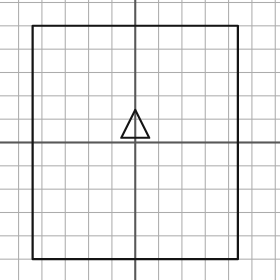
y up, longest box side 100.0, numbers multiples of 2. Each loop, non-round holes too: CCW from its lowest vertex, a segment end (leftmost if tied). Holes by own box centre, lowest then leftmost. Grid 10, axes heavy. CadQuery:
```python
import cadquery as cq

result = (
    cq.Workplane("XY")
    .moveTo(-44.0, -50.0)
    .lineTo(44.0, -50.0)
    .lineTo(44.0, 50.0)
    .lineTo(-44.0, 50.0)
    .close()
    .moveTo(-6.0, 2.0)
    .lineTo(6.0, 2.0)
    .lineTo(0.0, 14.0)
    .close()
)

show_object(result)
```